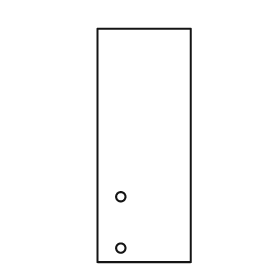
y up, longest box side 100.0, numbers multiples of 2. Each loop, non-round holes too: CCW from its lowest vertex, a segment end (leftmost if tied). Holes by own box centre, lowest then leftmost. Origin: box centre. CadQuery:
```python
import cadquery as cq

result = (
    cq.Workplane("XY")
    .moveTo(-20.0, -50.0)
    .lineTo(20.0, -50.0)
    .lineTo(20.0, 50.0)
    .lineTo(-20.0, 50.0)
    .close()
    .moveTo(-10.0, -44.0)
    .circle(2.0)
    .moveTo(-10.0, -22.0)
    .circle(2.0)
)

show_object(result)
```